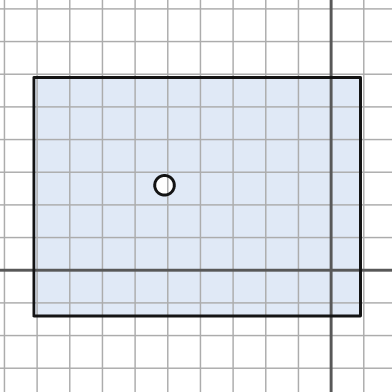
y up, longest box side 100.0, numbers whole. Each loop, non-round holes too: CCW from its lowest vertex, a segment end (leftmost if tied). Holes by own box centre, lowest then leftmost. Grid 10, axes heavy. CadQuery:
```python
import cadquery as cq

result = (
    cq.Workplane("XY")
    .moveTo(-91.0, -14.0)
    .lineTo(9.0, -14.0)
    .lineTo(9.0, 59.0)
    .lineTo(-91.0, 59.0)
    .close()
    .moveTo(-51.0, 26.0)
    .circle(3.0)
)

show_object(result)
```